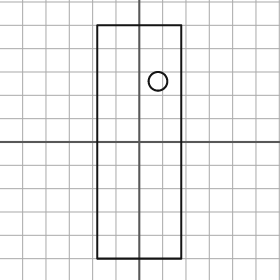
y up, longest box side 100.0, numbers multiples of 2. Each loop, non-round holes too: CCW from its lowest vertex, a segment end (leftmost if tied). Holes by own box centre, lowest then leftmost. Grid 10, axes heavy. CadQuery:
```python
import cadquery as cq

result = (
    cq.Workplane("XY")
    .moveTo(-18.0, -50.0)
    .lineTo(18.0, -50.0)
    .lineTo(18.0, 50.0)
    .lineTo(-18.0, 50.0)
    .close()
    .moveTo(8.0, 26.0)
    .circle(4.0)
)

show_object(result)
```